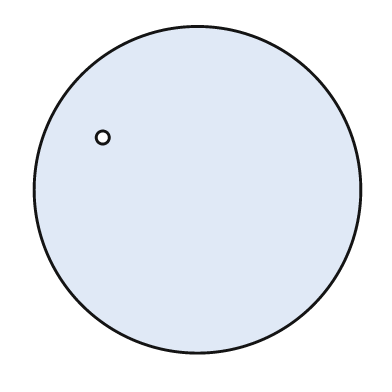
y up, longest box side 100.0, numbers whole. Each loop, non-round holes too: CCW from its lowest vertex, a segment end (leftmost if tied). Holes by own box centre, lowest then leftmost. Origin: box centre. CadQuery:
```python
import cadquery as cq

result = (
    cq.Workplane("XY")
    .moveTo(0.0, 0.0)
    .circle(50.0)
    .moveTo(-29.0, 16.0)
    .circle(2.0)
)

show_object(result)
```